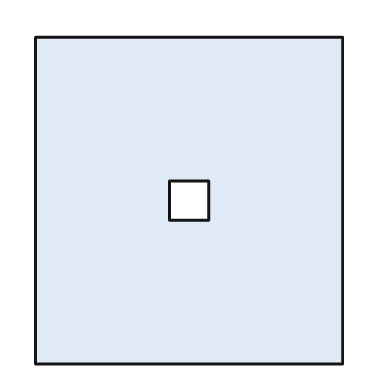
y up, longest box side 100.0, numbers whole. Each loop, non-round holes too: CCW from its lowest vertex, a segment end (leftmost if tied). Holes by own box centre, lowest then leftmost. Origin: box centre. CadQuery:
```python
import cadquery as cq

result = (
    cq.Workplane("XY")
    .moveTo(-47.0, -50.0)
    .lineTo(47.0, -50.0)
    .lineTo(47.0, 50.0)
    .lineTo(-47.0, 50.0)
    .close()
    .moveTo(-6.0, -6.0)
    .lineTo(6.0, -6.0)
    .lineTo(6.0, 6.0)
    .lineTo(-6.0, 6.0)
    .close()
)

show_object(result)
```